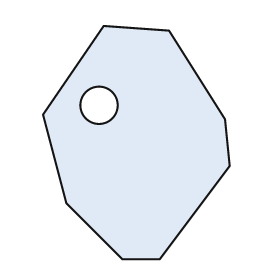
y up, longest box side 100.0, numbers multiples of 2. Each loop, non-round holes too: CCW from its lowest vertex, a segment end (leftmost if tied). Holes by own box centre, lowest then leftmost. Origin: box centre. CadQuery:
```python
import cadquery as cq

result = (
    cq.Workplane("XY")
    .moveTo(-6.0, -50.0)
    .lineTo(10.0, -50.0)
    .lineTo(40.0, -10.0)
    .lineTo(38.0, 10.0)
    .lineTo(14.0, 48.0)
    .lineTo(-14.0, 50.0)
    .lineTo(-40.0, 12.0)
    .lineTo(-30.0, -26.0)
    .close()
    .moveTo(-16.0, 16.0)
    .circle(8.0)
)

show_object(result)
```